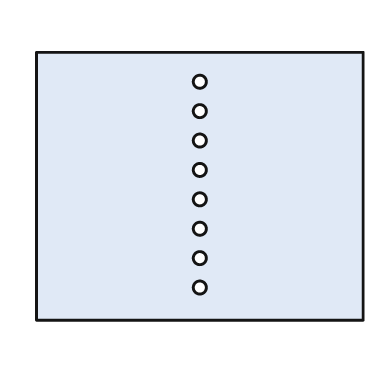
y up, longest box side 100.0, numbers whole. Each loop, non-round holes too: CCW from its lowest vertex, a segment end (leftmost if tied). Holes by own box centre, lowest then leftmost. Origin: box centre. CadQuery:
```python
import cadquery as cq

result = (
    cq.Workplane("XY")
    .moveTo(-50.0, -41.0)
    .lineTo(50.0, -41.0)
    .lineTo(50.0, 41.0)
    .lineTo(-50.0, 41.0)
    .close()
    .moveTo(0.0, -31.0)
    .circle(2.0)
    .moveTo(0.0, -22.0)
    .circle(2.0)
    .moveTo(0.0, -13.0)
    .circle(2.0)
    .moveTo(0.0, -4.0)
    .circle(2.0)
    .moveTo(0.0, 5.0)
    .circle(2.0)
    .moveTo(0.0, 14.0)
    .circle(2.0)
    .moveTo(0.0, 23.0)
    .circle(2.0)
    .moveTo(0.0, 32.0)
    .circle(2.0)
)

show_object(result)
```